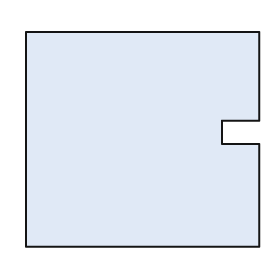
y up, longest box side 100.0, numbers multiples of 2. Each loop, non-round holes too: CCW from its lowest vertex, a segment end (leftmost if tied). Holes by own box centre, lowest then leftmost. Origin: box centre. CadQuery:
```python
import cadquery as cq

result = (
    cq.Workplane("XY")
    .moveTo(-50.0, -46.0)
    .lineTo(50.0, -46.0)
    .lineTo(50.0, -2.0)
    .lineTo(34.0, -2.0)
    .lineTo(34.0, 8.0)
    .lineTo(50.0, 8.0)
    .lineTo(50.0, 46.0)
    .lineTo(-50.0, 46.0)
    .close()
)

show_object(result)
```